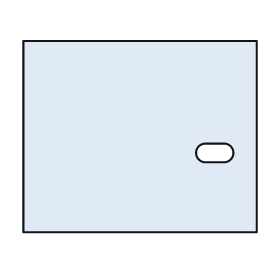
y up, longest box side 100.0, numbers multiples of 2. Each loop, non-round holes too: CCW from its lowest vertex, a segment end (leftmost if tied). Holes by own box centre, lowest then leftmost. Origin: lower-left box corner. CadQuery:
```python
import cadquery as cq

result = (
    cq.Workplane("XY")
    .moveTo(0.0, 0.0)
    .lineTo(100.0, 0.0)
    .lineTo(100.0, 82.0)
    .lineTo(0.0, 82.0)
    .close()
    .moveTo(78.0, 30.0)
    .lineTo(86.0, 30.0)
    .threePointArc((90.0, 34.0), (86.0, 38.0))
    .lineTo(78.0, 38.0)
    .threePointArc((74.0, 34.0), (78.0, 30.0))
    .close()
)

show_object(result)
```